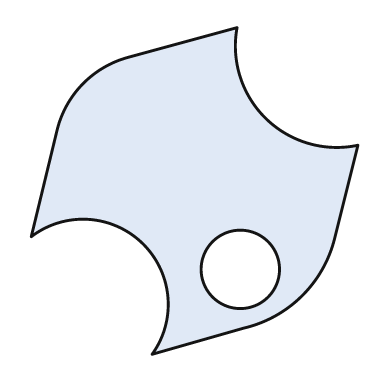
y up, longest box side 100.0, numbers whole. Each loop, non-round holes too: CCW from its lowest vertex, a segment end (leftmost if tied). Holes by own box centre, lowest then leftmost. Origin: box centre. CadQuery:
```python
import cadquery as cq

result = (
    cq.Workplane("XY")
    .moveTo(-13.0, -50.0)
    .lineTo(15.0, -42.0)
    .threePointArc((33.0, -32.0), (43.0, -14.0))
    .lineTo(50.0, 14.0)
    .threePointArc((22.0, 22.0), (13.0, 50.0))
    .lineTo(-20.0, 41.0)
    .threePointArc((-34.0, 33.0), (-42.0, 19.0))
    .lineTo(-50.0, -14.0)
    .threePointArc((-16.0, -16.0), (-13.0, -50.0))
    .close()
    .moveTo(14.0, -24.0)
    .circle(12.0)
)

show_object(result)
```